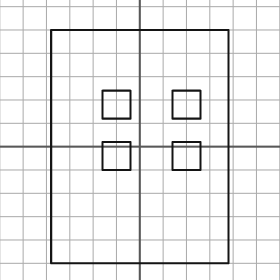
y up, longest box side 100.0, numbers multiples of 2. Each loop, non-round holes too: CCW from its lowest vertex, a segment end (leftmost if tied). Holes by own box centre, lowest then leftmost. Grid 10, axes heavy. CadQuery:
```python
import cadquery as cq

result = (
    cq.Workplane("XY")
    .moveTo(-38.0, -50.0)
    .lineTo(38.0, -50.0)
    .lineTo(38.0, 50.0)
    .lineTo(-38.0, 50.0)
    .close()
    .moveTo(-16.0, -10.0)
    .lineTo(-4.0, -10.0)
    .lineTo(-4.0, 2.0)
    .lineTo(-16.0, 2.0)
    .close()
    .moveTo(14.0, -10.0)
    .lineTo(26.0, -10.0)
    .lineTo(26.0, 2.0)
    .lineTo(14.0, 2.0)
    .close()
    .moveTo(-16.0, 12.0)
    .lineTo(-4.0, 12.0)
    .lineTo(-4.0, 24.0)
    .lineTo(-16.0, 24.0)
    .close()
    .moveTo(14.0, 12.0)
    .lineTo(26.0, 12.0)
    .lineTo(26.0, 24.0)
    .lineTo(14.0, 24.0)
    .close()
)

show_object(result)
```